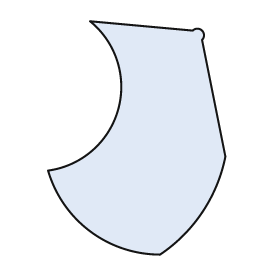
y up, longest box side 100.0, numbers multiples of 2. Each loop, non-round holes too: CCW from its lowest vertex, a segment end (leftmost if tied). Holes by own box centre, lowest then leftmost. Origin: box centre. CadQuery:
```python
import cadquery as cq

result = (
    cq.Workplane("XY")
    .moveTo(10.0, -50.0)
    .threePointArc((28.0, -32.0), (38.0, -8.0))
    .lineTo(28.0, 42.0)
    .threePointArc((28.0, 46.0), (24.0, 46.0))
    .lineTo(-20.0, 50.0)
    .threePointArc((-8.0, 12.0), (-38.0, -14.0))
    .threePointArc((-20.0, -40.0), (10.0, -50.0))
    .close()
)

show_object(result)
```